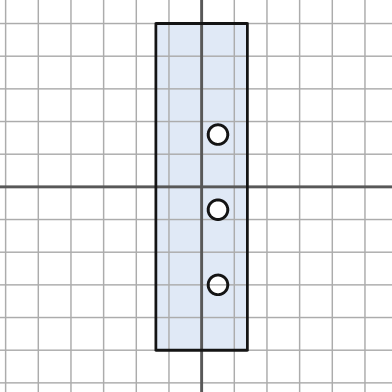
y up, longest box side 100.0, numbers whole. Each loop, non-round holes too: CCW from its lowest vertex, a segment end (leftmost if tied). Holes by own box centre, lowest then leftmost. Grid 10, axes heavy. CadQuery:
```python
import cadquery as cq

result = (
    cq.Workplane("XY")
    .moveTo(-14.0, -50.0)
    .lineTo(14.0, -50.0)
    .lineTo(14.0, 50.0)
    .lineTo(-14.0, 50.0)
    .close()
    .moveTo(5.0, -30.0)
    .circle(3.0)
    .moveTo(5.0, -7.0)
    .circle(3.0)
    .moveTo(5.0, 16.0)
    .circle(3.0)
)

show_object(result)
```